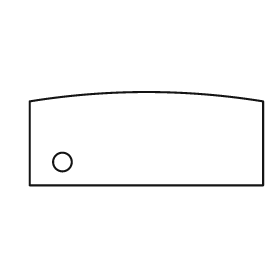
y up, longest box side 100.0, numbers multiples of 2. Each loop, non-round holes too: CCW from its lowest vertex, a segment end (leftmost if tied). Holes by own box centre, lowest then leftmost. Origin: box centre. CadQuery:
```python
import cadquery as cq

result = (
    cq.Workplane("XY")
    .moveTo(-50.0, -20.0)
    .lineTo(50.0, -20.0)
    .lineTo(50.0, 16.0)
    .threePointArc((0.0, 20.0), (-50.0, 16.0))
    .close()
    .moveTo(-36.0, -10.0)
    .circle(4.0)
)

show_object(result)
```